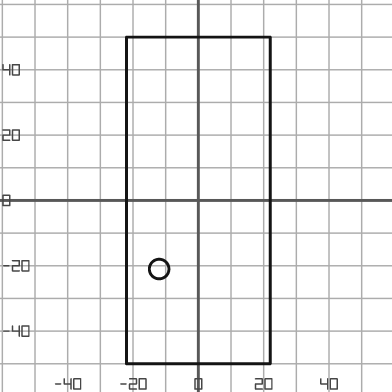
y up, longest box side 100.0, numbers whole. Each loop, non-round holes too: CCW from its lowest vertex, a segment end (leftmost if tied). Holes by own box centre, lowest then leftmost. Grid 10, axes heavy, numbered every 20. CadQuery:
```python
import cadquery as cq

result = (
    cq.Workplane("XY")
    .moveTo(-22.0, -50.0)
    .lineTo(22.0, -50.0)
    .lineTo(22.0, 50.0)
    .lineTo(-22.0, 50.0)
    .close()
    .moveTo(-12.0, -21.0)
    .circle(3.0)
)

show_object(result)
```